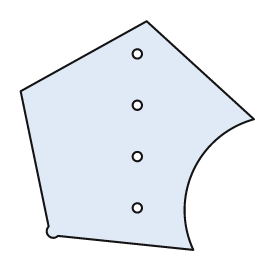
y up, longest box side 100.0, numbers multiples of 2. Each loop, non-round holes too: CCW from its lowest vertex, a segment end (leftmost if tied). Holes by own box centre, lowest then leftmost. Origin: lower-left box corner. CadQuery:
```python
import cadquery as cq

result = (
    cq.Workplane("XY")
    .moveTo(74.0, 0.0)
    .threePointArc((74.0, 34.0), (100.0, 56.0))
    .lineTo(54.0, 98.0)
    .lineTo(0.0, 68.0)
    .lineTo(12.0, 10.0)
    .threePointArc((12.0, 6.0), (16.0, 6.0))
    .close()
    .moveTo(50.0, 18.0)
    .circle(2.0)
    .moveTo(50.0, 40.0)
    .circle(2.0)
    .moveTo(50.0, 62.0)
    .circle(2.0)
    .moveTo(50.0, 84.0)
    .circle(2.0)
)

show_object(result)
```